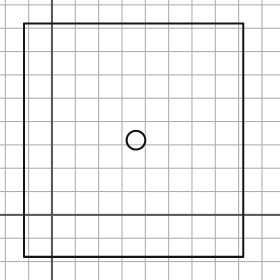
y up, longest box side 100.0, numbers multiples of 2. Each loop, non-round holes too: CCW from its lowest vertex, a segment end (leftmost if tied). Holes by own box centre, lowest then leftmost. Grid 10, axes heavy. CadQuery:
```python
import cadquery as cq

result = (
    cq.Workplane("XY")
    .moveTo(-12.0, -18.0)
    .lineTo(82.0, -18.0)
    .lineTo(82.0, 82.0)
    .lineTo(-12.0, 82.0)
    .close()
    .moveTo(36.0, 32.0)
    .circle(4.0)
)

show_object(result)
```